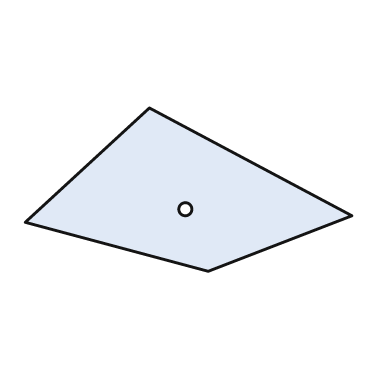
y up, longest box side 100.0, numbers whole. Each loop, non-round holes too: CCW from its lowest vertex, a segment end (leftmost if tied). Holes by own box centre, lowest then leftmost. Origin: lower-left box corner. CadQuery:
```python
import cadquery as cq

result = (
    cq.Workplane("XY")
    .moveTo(56.0, 0.0)
    .lineTo(100.0, 17.0)
    .lineTo(38.0, 50.0)
    .lineTo(0.0, 15.0)
    .close()
    .moveTo(49.0, 19.0)
    .circle(2.0)
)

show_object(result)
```